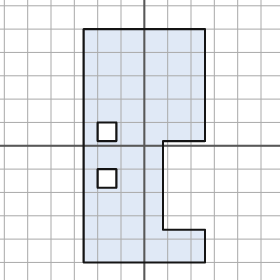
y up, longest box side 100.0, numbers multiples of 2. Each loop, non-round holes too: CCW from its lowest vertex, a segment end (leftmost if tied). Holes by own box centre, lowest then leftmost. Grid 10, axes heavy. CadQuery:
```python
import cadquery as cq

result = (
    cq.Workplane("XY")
    .moveTo(-26.0, -50.0)
    .lineTo(26.0, -50.0)
    .lineTo(26.0, -36.0)
    .lineTo(8.0, -36.0)
    .lineTo(8.0, 2.0)
    .lineTo(26.0, 2.0)
    .lineTo(26.0, 50.0)
    .lineTo(-26.0, 50.0)
    .close()
    .moveTo(-20.0, -18.0)
    .lineTo(-12.0, -18.0)
    .lineTo(-12.0, -10.0)
    .lineTo(-20.0, -10.0)
    .close()
    .moveTo(-20.0, 2.0)
    .lineTo(-12.0, 2.0)
    .lineTo(-12.0, 10.0)
    .lineTo(-20.0, 10.0)
    .close()
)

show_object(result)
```